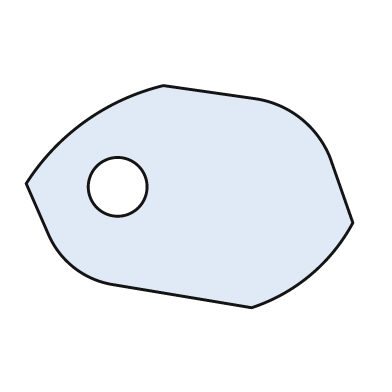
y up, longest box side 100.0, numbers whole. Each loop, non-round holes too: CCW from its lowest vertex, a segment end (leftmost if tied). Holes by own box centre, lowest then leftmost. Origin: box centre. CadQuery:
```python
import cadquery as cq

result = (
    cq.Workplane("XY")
    .moveTo(19.0, -34.0)
    .threePointArc((37.0, -24.0), (50.0, -8.0))
    .lineTo(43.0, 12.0)
    .threePointArc((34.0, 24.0), (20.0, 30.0))
    .lineTo(-8.0, 34.0)
    .threePointArc((-32.0, 23.0), (-50.0, 4.0))
    .lineTo(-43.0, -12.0)
    .threePointArc((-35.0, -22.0), (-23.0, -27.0))
    .close()
    .moveTo(-22.0, 3.0)
    .circle(9.0)
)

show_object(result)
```